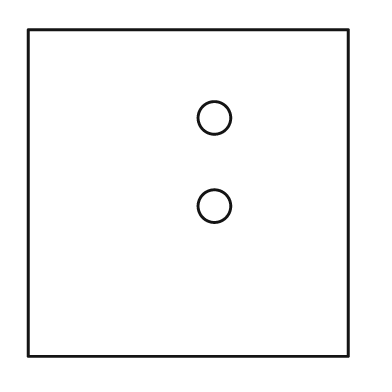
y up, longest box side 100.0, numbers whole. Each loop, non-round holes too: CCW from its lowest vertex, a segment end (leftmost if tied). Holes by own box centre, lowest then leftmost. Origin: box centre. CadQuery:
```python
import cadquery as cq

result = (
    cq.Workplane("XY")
    .moveTo(-49.0, -50.0)
    .lineTo(49.0, -50.0)
    .lineTo(49.0, 50.0)
    .lineTo(-49.0, 50.0)
    .close()
    .moveTo(8.0, -4.0)
    .circle(5.0)
    .moveTo(8.0, 23.0)
    .circle(5.0)
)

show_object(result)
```